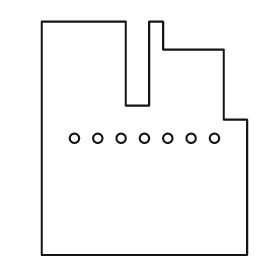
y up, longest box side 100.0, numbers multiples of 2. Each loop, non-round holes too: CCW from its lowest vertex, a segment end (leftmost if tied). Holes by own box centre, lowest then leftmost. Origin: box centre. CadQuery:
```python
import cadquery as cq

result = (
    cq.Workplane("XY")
    .moveTo(-44.0, -50.0)
    .lineTo(44.0, -50.0)
    .lineTo(44.0, 8.0)
    .lineTo(34.0, 8.0)
    .lineTo(34.0, 38.0)
    .lineTo(8.0, 38.0)
    .lineTo(8.0, 50.0)
    .lineTo(2.0, 50.0)
    .lineTo(2.0, 14.0)
    .lineTo(-8.0, 14.0)
    .lineTo(-8.0, 50.0)
    .lineTo(-44.0, 50.0)
    .close()
    .moveTo(-30.0, 0.0)
    .circle(2.0)
    .moveTo(-20.0, 0.0)
    .circle(2.0)
    .moveTo(-10.0, 0.0)
    .circle(2.0)
    .moveTo(0.0, 0.0)
    .circle(2.0)
    .moveTo(10.0, 0.0)
    .circle(2.0)
    .moveTo(20.0, 0.0)
    .circle(2.0)
    .moveTo(30.0, 0.0)
    .circle(2.0)
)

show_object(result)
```